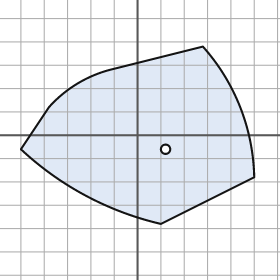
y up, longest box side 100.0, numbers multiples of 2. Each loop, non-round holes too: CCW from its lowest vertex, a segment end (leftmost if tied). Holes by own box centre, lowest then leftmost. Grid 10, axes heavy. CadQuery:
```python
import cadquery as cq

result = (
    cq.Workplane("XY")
    .moveTo(10.0, -38.0)
    .lineTo(50.0, -18.0)
    .threePointArc((44.0, 12.0), (28.0, 38.0))
    .lineTo(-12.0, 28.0)
    .threePointArc((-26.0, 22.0), (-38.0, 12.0))
    .lineTo(-50.0, -6.0)
    .threePointArc((-22.0, -26.0), (10.0, -38.0))
    .close()
    .moveTo(12.0, -6.0)
    .circle(2.0)
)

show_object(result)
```